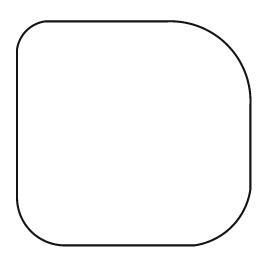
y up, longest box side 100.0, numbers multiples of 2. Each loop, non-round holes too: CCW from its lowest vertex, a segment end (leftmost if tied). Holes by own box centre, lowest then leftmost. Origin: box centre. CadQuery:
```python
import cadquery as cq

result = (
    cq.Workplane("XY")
    .moveTo(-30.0, -48.0)
    .lineTo(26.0, -48.0)
    .threePointArc((42.0, -40.0), (50.0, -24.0))
    .lineTo(50.0, 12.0)
    .threePointArc((40.0, 38.0), (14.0, 48.0))
    .lineTo(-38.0, 48.0)
    .threePointArc((-46.0, 44.0), (-50.0, 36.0))
    .lineTo(-50.0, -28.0)
    .threePointArc((-44.0, -42.0), (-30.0, -48.0))
    .close()
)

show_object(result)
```